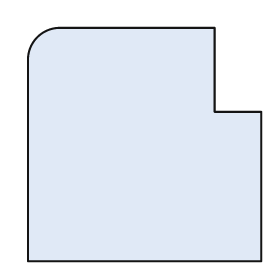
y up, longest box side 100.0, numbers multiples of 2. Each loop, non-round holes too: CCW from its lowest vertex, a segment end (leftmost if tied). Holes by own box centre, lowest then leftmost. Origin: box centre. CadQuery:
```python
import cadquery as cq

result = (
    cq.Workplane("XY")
    .moveTo(-50.0, -50.0)
    .lineTo(50.0, -50.0)
    .lineTo(50.0, 14.0)
    .lineTo(30.0, 14.0)
    .lineTo(30.0, 50.0)
    .lineTo(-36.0, 50.0)
    .threePointArc((-46.0, 46.0), (-50.0, 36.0))
    .close()
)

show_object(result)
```